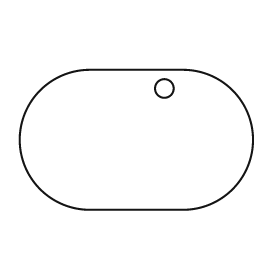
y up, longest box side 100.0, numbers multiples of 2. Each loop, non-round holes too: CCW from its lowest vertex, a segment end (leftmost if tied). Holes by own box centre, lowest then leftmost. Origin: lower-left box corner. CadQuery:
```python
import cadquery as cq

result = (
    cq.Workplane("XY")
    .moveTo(30.0, 0.0)
    .lineTo(70.0, 0.0)
    .threePointArc((100.0, 30.0), (70.0, 60.0))
    .lineTo(30.0, 60.0)
    .threePointArc((0.0, 30.0), (30.0, 0.0))
    .close()
    .moveTo(62.0, 52.0)
    .circle(4.0)
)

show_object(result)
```